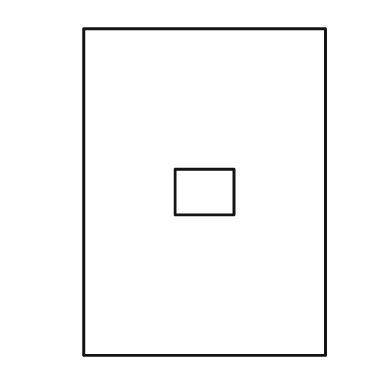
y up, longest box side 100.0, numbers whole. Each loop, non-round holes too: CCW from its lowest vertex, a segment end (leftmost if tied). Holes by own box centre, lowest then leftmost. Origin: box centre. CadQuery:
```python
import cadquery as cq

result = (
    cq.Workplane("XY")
    .moveTo(-37.0, -50.0)
    .lineTo(37.0, -50.0)
    .lineTo(37.0, 50.0)
    .lineTo(-37.0, 50.0)
    .close()
    .moveTo(-9.0, -7.0)
    .lineTo(9.0, -7.0)
    .lineTo(9.0, 7.0)
    .lineTo(-9.0, 7.0)
    .close()
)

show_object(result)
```